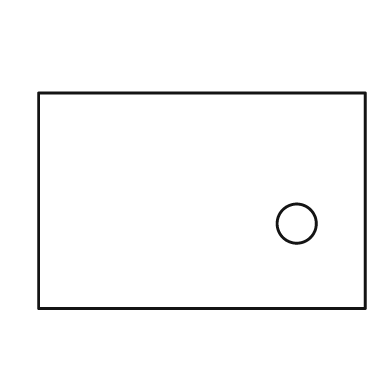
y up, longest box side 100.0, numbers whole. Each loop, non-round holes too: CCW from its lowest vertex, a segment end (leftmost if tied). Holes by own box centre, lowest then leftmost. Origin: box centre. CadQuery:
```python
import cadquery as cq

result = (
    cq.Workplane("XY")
    .moveTo(-50.0, -33.0)
    .lineTo(50.0, -33.0)
    .lineTo(50.0, 33.0)
    .lineTo(-50.0, 33.0)
    .close()
    .moveTo(29.0, -7.0)
    .circle(6.0)
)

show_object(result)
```